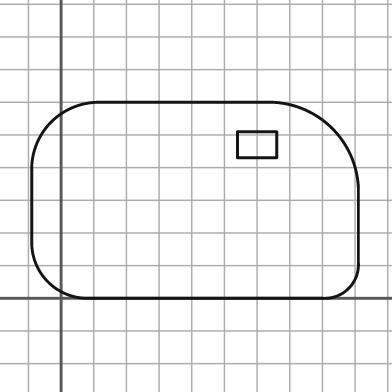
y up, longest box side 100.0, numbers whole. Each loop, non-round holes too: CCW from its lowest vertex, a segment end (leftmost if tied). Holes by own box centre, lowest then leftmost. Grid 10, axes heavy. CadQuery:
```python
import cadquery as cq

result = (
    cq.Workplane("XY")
    .moveTo(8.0, 0.0)
    .lineTo(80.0, 0.0)
    .threePointArc((88.0, 3.0), (91.0, 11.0))
    .lineTo(91.0, 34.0)
    .threePointArc((83.0, 52.0), (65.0, 60.0))
    .lineTo(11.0, 60.0)
    .threePointArc((-3.0, 54.0), (-9.0, 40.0))
    .lineTo(-9.0, 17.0)
    .threePointArc((-4.0, 5.0), (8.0, 0.0))
    .close()
    .moveTo(54.0, 43.0)
    .lineTo(66.0, 43.0)
    .lineTo(66.0, 51.0)
    .lineTo(54.0, 51.0)
    .close()
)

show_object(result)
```